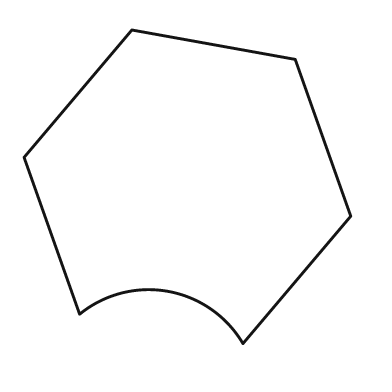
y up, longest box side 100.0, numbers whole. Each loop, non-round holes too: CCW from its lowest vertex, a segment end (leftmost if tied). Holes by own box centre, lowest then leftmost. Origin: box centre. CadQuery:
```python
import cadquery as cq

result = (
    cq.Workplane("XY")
    .moveTo(17.0, -48.0)
    .lineTo(50.0, -9.0)
    .lineTo(33.0, 39.0)
    .lineTo(-17.0, 48.0)
    .lineTo(-50.0, 9.0)
    .lineTo(-33.0, -39.0)
    .threePointArc((-6.0, -32.0), (17.0, -48.0))
    .close()
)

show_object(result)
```